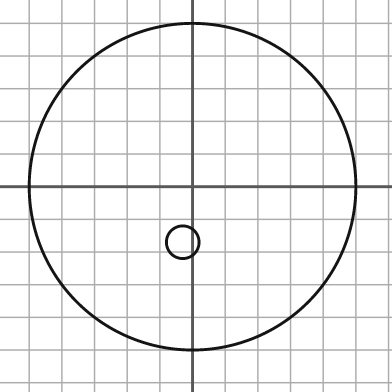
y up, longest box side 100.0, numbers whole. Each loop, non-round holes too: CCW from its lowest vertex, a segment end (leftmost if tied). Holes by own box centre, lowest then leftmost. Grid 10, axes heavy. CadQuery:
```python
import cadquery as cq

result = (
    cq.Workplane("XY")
    .moveTo(0.0, 0.0)
    .circle(50.0)
    .moveTo(-3.0, -17.0)
    .circle(5.0)
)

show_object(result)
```